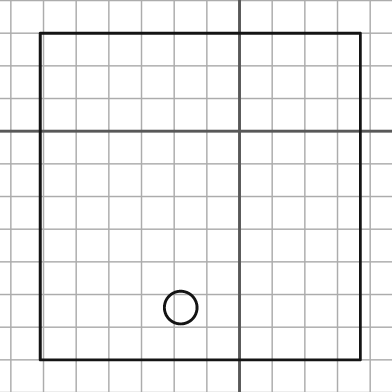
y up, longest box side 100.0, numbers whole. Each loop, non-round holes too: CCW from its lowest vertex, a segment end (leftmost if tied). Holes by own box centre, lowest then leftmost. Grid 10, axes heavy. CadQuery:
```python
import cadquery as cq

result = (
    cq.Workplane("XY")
    .moveTo(-61.0, -70.0)
    .lineTo(37.0, -70.0)
    .lineTo(37.0, 30.0)
    .lineTo(-61.0, 30.0)
    .close()
    .moveTo(-18.0, -54.0)
    .circle(5.0)
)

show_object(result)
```